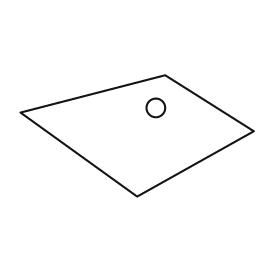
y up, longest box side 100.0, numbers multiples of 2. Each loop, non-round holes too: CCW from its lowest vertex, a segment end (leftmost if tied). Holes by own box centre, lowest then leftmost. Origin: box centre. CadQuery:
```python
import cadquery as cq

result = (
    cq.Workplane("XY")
    .moveTo(0.0, -26.0)
    .lineTo(50.0, 2.0)
    .lineTo(12.0, 26.0)
    .lineTo(-50.0, 10.0)
    .close()
    .moveTo(8.0, 12.0)
    .circle(4.0)
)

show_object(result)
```